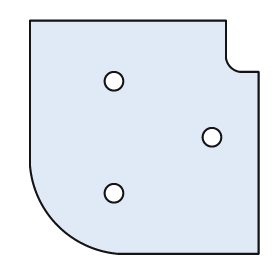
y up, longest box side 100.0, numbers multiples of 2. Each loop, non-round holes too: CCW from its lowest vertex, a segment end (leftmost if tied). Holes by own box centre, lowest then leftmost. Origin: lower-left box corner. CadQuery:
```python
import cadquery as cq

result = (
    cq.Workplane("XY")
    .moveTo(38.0, 0.0)
    .lineTo(98.0, 0.0)
    .lineTo(98.0, 78.0)
    .lineTo(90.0, 78.0)
    .threePointArc((86.0, 80.0), (84.0, 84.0))
    .lineTo(84.0, 100.0)
    .lineTo(0.0, 100.0)
    .lineTo(0.0, 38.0)
    .threePointArc((12.0, 12.0), (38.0, 0.0))
    .close()
    .moveTo(36.0, 26.0)
    .circle(4.0)
    .moveTo(78.0, 50.0)
    .circle(4.0)
    .moveTo(36.0, 74.0)
    .circle(4.0)
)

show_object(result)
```